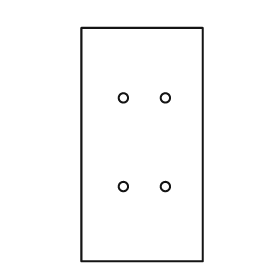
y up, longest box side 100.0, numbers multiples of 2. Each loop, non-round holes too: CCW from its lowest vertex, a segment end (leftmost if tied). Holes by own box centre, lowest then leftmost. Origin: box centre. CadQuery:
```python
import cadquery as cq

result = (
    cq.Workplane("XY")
    .moveTo(-26.0, -50.0)
    .lineTo(26.0, -50.0)
    .lineTo(26.0, 50.0)
    .lineTo(-26.0, 50.0)
    .close()
    .moveTo(-8.0, -18.0)
    .circle(2.0)
    .moveTo(10.0, -18.0)
    .circle(2.0)
    .moveTo(-8.0, 20.0)
    .circle(2.0)
    .moveTo(10.0, 20.0)
    .circle(2.0)
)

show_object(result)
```